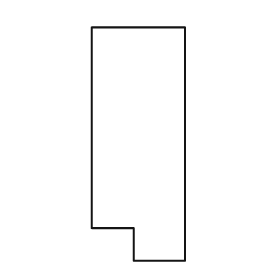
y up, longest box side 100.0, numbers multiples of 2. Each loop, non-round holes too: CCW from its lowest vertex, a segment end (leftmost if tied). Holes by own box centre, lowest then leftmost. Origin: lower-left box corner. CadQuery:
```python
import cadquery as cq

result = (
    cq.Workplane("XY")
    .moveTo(18.0, 0.0)
    .lineTo(40.0, 0.0)
    .lineTo(40.0, 100.0)
    .lineTo(0.0, 100.0)
    .lineTo(0.0, 14.0)
    .lineTo(18.0, 14.0)
    .close()
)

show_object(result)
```